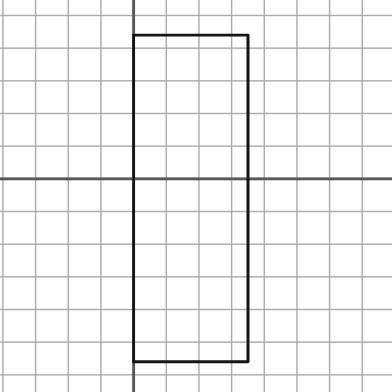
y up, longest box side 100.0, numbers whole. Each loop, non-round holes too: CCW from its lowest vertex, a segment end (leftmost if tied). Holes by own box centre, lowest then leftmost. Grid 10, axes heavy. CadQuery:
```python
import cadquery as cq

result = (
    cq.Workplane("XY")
    .moveTo(0.0, -56.0)
    .lineTo(35.0, -56.0)
    .lineTo(35.0, 44.0)
    .lineTo(0.0, 44.0)
    .close()
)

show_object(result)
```